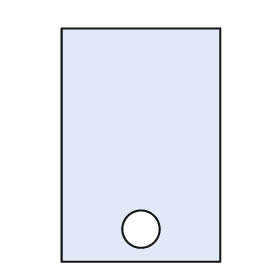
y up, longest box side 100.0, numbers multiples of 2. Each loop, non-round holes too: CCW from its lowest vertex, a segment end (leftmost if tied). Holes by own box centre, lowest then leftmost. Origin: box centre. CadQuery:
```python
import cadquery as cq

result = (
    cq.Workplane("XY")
    .moveTo(-34.0, -50.0)
    .lineTo(34.0, -50.0)
    .lineTo(34.0, 50.0)
    .lineTo(-34.0, 50.0)
    .close()
    .moveTo(0.0, -36.0)
    .circle(8.0)
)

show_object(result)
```